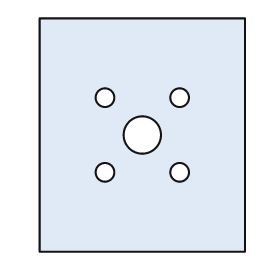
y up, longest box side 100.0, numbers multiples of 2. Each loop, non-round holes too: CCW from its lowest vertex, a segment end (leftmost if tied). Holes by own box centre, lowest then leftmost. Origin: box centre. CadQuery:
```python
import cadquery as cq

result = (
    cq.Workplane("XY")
    .moveTo(-44.0, -50.0)
    .lineTo(44.0, -50.0)
    .lineTo(44.0, 50.0)
    .lineTo(-44.0, 50.0)
    .close()
    .moveTo(-16.0, -16.0)
    .circle(4.0)
    .moveTo(16.0, -16.0)
    .circle(4.0)
    .moveTo(0.0, 0.0)
    .circle(8.0)
    .moveTo(-16.0, 16.0)
    .circle(4.0)
    .moveTo(16.0, 16.0)
    .circle(4.0)
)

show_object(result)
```